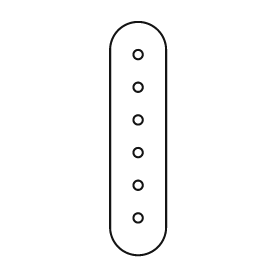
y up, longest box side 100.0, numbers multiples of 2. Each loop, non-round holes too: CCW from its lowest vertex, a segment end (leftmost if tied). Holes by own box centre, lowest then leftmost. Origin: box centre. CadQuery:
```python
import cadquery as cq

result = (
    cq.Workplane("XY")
    .moveTo(-12.0, -38.0)
    .threePointArc((0.0, -50.0), (12.0, -38.0))
    .lineTo(12.0, 38.0)
    .threePointArc((0.0, 50.0), (-12.0, 38.0))
    .close()
    .moveTo(0.0, -34.0)
    .circle(2.0)
    .moveTo(0.0, -20.0)
    .circle(2.0)
    .moveTo(0.0, -6.0)
    .circle(2.0)
    .moveTo(0.0, 8.0)
    .circle(2.0)
    .moveTo(0.0, 22.0)
    .circle(2.0)
    .moveTo(0.0, 36.0)
    .circle(2.0)
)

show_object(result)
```